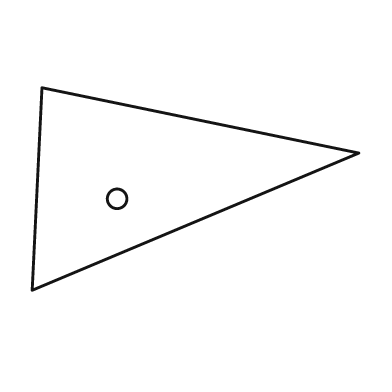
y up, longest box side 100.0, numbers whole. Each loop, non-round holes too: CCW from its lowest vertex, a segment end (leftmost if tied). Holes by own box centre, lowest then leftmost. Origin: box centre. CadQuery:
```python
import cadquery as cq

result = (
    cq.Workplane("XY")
    .moveTo(-50.0, -31.0)
    .lineTo(50.0, 11.0)
    .lineTo(-47.0, 31.0)
    .close()
    .moveTo(-24.0, -3.0)
    .circle(3.0)
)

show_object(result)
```